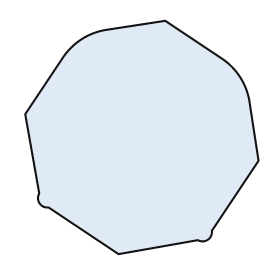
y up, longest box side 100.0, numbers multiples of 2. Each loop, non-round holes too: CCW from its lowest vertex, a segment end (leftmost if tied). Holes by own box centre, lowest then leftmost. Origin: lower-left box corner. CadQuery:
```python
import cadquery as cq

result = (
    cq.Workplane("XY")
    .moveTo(40.0, 0.0)
    .lineTo(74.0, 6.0)
    .threePointArc((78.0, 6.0), (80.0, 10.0))
    .lineTo(100.0, 40.0)
    .lineTo(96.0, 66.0)
    .threePointArc((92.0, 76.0), (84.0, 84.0))
    .lineTo(60.0, 100.0)
    .lineTo(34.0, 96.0)
    .threePointArc((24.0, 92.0), (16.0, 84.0))
    .lineTo(0.0, 60.0)
    .lineTo(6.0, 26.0)
    .threePointArc((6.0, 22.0), (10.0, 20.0))
    .close()
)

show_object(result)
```